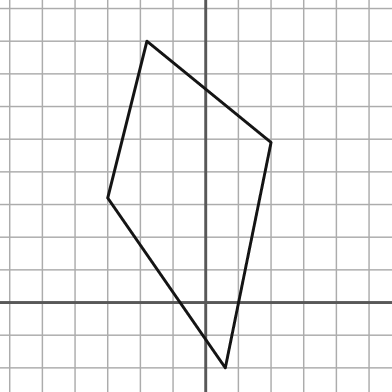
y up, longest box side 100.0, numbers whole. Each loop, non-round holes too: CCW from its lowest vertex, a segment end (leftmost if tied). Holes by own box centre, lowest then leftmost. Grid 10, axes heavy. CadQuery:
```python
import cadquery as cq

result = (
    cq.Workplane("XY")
    .moveTo(6.0, -20.0)
    .lineTo(20.0, 49.0)
    .lineTo(-18.0, 80.0)
    .lineTo(-30.0, 32.0)
    .close()
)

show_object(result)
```